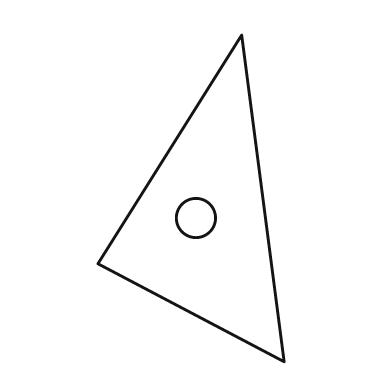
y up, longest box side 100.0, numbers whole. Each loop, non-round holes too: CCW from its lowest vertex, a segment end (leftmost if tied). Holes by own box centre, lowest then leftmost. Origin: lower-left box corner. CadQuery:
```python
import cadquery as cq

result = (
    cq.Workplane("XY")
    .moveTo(57.0, 0.0)
    .lineTo(44.0, 100.0)
    .lineTo(0.0, 30.0)
    .close()
    .moveTo(30.0, 44.0)
    .circle(6.0)
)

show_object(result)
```